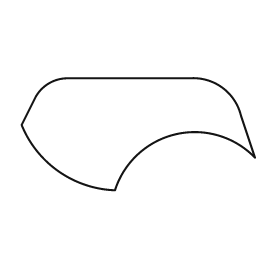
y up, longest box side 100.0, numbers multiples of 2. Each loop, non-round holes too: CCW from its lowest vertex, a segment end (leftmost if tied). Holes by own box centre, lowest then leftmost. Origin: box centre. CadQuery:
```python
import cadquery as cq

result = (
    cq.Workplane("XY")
    .moveTo(-10.0, -24.0)
    .threePointArc((16.0, 0.0), (50.0, -10.0))
    .lineTo(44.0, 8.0)
    .threePointArc((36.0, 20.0), (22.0, 24.0))
    .lineTo(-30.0, 24.0)
    .threePointArc((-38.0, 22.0), (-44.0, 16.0))
    .lineTo(-50.0, 4.0)
    .threePointArc((-34.0, -16.0), (-10.0, -24.0))
    .close()
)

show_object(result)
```